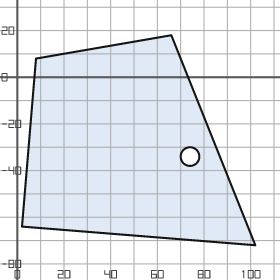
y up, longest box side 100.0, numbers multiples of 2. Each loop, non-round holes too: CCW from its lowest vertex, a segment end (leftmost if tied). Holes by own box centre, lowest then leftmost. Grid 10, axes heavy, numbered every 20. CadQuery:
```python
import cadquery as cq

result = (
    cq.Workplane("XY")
    .moveTo(102.0, -72.0)
    .lineTo(66.0, 18.0)
    .lineTo(8.0, 8.0)
    .lineTo(2.0, -64.0)
    .close()
    .moveTo(74.0, -34.0)
    .circle(4.0)
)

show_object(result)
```